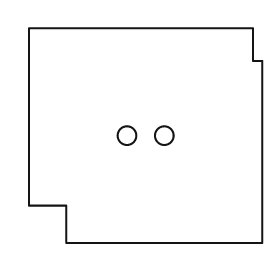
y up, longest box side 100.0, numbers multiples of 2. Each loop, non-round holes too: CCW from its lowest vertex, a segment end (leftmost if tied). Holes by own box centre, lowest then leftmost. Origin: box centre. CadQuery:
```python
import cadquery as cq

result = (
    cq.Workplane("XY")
    .moveTo(-34.0, -46.0)
    .lineTo(50.0, -46.0)
    .lineTo(50.0, 32.0)
    .lineTo(46.0, 32.0)
    .lineTo(46.0, 46.0)
    .lineTo(-50.0, 46.0)
    .lineTo(-50.0, -30.0)
    .lineTo(-34.0, -30.0)
    .close()
    .moveTo(-8.0, 0.0)
    .circle(4.0)
    .moveTo(8.0, 0.0)
    .circle(4.0)
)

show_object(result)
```